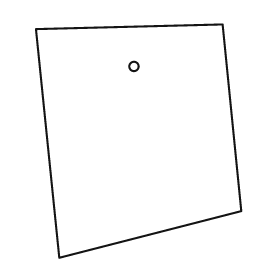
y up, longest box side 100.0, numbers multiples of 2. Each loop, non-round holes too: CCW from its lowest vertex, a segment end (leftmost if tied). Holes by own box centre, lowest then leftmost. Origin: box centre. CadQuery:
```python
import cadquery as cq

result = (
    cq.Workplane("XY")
    .moveTo(-34.0, -50.0)
    .lineTo(44.0, -30.0)
    .lineTo(36.0, 50.0)
    .lineTo(-44.0, 48.0)
    .close()
    .moveTo(-2.0, 32.0)
    .circle(2.0)
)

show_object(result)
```